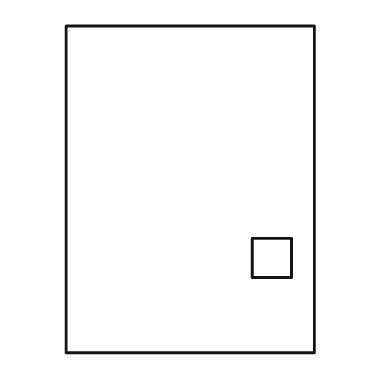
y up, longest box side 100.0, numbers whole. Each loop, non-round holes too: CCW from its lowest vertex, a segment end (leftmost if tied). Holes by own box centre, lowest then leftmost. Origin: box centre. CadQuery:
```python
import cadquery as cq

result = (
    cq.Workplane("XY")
    .moveTo(-38.0, -50.0)
    .lineTo(38.0, -50.0)
    .lineTo(38.0, 50.0)
    .lineTo(-38.0, 50.0)
    .close()
    .moveTo(19.0, -27.0)
    .lineTo(31.0, -27.0)
    .lineTo(31.0, -15.0)
    .lineTo(19.0, -15.0)
    .close()
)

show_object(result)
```